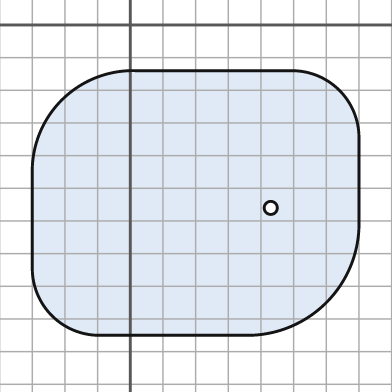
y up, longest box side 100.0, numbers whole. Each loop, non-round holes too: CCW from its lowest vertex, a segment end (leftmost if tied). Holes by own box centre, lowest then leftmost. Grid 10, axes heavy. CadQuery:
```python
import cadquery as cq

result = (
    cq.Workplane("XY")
    .moveTo(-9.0, -95.0)
    .lineTo(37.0, -95.0)
    .threePointArc((60.0, -85.0), (70.0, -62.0))
    .lineTo(70.0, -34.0)
    .threePointArc((64.0, -20.0), (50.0, -14.0))
    .lineTo(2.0, -14.0)
    .threePointArc((-21.0, -23.0), (-30.0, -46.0))
    .lineTo(-30.0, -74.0)
    .threePointArc((-24.0, -89.0), (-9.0, -95.0))
    .close()
    .moveTo(43.0, -56.0)
    .circle(2.0)
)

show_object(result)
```